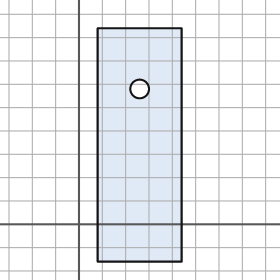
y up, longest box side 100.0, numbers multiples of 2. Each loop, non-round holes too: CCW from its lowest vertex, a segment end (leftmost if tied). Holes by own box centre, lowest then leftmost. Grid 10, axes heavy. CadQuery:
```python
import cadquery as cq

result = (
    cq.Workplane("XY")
    .moveTo(8.0, -16.0)
    .lineTo(44.0, -16.0)
    .lineTo(44.0, 84.0)
    .lineTo(8.0, 84.0)
    .close()
    .moveTo(26.0, 58.0)
    .circle(4.0)
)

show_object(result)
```